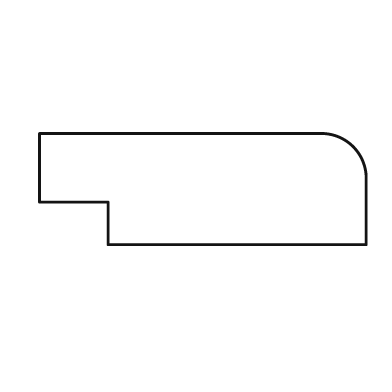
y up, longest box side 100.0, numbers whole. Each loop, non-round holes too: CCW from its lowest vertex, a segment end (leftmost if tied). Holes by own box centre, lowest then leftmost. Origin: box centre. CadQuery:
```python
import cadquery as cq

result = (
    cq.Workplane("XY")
    .moveTo(-29.0, -17.0)
    .lineTo(50.0, -17.0)
    .lineTo(50.0, 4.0)
    .threePointArc((46.0, 13.0), (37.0, 17.0))
    .lineTo(-50.0, 17.0)
    .lineTo(-50.0, -4.0)
    .lineTo(-29.0, -4.0)
    .close()
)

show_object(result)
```